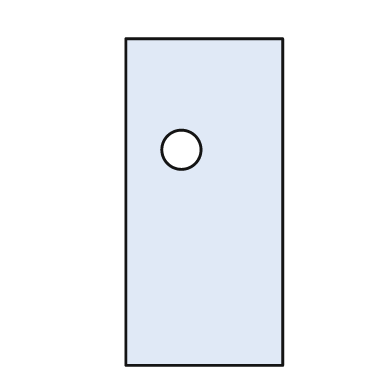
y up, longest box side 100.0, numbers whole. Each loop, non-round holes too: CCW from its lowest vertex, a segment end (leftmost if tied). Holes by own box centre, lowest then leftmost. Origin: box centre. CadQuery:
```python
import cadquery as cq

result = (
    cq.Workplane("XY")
    .moveTo(-24.0, -50.0)
    .lineTo(24.0, -50.0)
    .lineTo(24.0, 50.0)
    .lineTo(-24.0, 50.0)
    .close()
    .moveTo(-7.0, 16.0)
    .circle(6.0)
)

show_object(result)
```